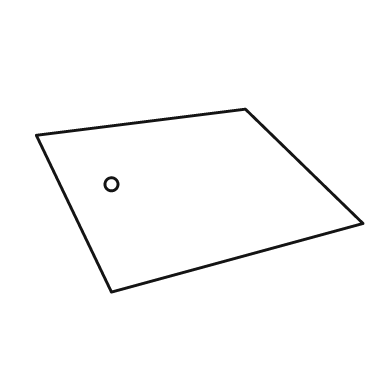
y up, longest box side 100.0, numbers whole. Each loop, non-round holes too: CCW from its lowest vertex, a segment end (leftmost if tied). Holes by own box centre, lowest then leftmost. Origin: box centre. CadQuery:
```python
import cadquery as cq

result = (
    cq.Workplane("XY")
    .moveTo(-27.0, -28.0)
    .lineTo(50.0, -7.0)
    .lineTo(14.0, 28.0)
    .lineTo(-50.0, 20.0)
    .close()
    .moveTo(-27.0, 5.0)
    .circle(2.0)
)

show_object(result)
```